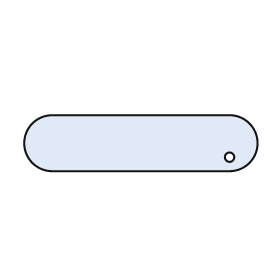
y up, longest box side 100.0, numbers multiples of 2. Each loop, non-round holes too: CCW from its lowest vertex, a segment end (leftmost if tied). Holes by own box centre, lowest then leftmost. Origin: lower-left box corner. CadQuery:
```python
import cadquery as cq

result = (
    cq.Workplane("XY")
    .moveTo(12.0, 0.0)
    .lineTo(88.0, 0.0)
    .threePointArc((100.0, 12.0), (88.0, 24.0))
    .lineTo(12.0, 24.0)
    .threePointArc((0.0, 12.0), (12.0, 0.0))
    .close()
    .moveTo(88.0, 6.0)
    .circle(2.0)
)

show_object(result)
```